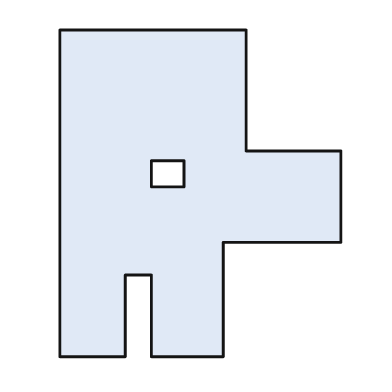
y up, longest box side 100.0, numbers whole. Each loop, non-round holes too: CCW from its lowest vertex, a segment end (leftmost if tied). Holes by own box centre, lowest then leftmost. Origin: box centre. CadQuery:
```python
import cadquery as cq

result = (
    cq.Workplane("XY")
    .moveTo(-43.0, -50.0)
    .lineTo(-23.0, -50.0)
    .lineTo(-23.0, -25.0)
    .lineTo(-15.0, -25.0)
    .lineTo(-15.0, -50.0)
    .lineTo(7.0, -50.0)
    .lineTo(7.0, -15.0)
    .lineTo(43.0, -15.0)
    .lineTo(43.0, 13.0)
    .lineTo(14.0, 13.0)
    .lineTo(14.0, 50.0)
    .lineTo(-43.0, 50.0)
    .close()
    .moveTo(-15.0, 2.0)
    .lineTo(-5.0, 2.0)
    .lineTo(-5.0, 10.0)
    .lineTo(-15.0, 10.0)
    .close()
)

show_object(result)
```